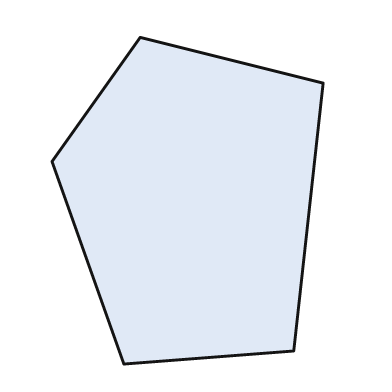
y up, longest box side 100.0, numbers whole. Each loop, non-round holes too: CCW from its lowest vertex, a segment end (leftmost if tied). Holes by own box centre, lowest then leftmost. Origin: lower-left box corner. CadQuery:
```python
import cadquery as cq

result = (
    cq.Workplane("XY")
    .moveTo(22.0, 0.0)
    .lineTo(74.0, 4.0)
    .lineTo(83.0, 86.0)
    .lineTo(27.0, 100.0)
    .lineTo(0.0, 62.0)
    .close()
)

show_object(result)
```